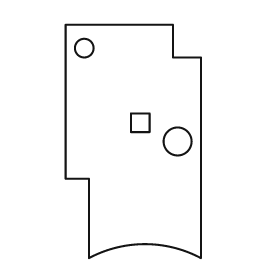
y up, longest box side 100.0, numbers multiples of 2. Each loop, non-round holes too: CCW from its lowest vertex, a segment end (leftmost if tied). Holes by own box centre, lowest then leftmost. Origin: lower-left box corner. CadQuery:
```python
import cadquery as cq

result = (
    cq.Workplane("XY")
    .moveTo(10.0, 0.0)
    .threePointArc((34.0, 6.0), (58.0, 0.0))
    .lineTo(58.0, 86.0)
    .lineTo(46.0, 86.0)
    .lineTo(46.0, 100.0)
    .lineTo(0.0, 100.0)
    .lineTo(0.0, 34.0)
    .lineTo(10.0, 34.0)
    .close()
    .moveTo(48.0, 50.0)
    .circle(6.0)
    .moveTo(28.0, 54.0)
    .lineTo(36.0, 54.0)
    .lineTo(36.0, 62.0)
    .lineTo(28.0, 62.0)
    .close()
    .moveTo(8.0, 90.0)
    .circle(4.0)
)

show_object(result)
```